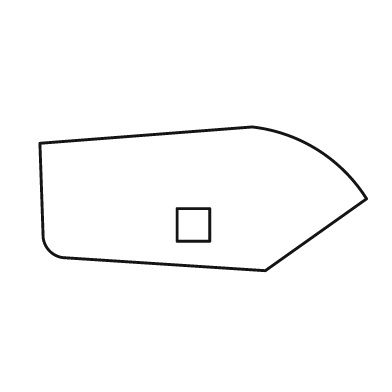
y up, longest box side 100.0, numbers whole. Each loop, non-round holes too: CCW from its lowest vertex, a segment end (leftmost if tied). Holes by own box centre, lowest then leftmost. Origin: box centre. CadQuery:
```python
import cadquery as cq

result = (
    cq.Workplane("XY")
    .moveTo(19.0, -22.0)
    .lineTo(50.0, 0.0)
    .threePointArc((35.0, 15.0), (15.0, 22.0))
    .lineTo(-50.0, 17.0)
    .lineTo(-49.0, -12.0)
    .threePointArc((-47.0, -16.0), (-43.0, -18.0))
    .close()
    .moveTo(-8.0, -13.0)
    .lineTo(2.0, -13.0)
    .lineTo(2.0, -3.0)
    .lineTo(-8.0, -3.0)
    .close()
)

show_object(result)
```